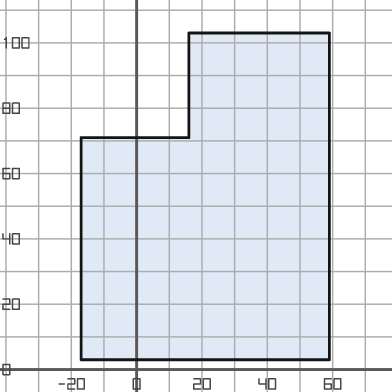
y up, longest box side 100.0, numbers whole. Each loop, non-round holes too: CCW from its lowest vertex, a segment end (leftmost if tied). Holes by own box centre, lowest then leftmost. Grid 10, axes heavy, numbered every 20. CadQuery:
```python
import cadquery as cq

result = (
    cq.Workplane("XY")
    .moveTo(-17.0, 3.0)
    .lineTo(59.0, 3.0)
    .lineTo(59.0, 103.0)
    .lineTo(16.0, 103.0)
    .lineTo(16.0, 71.0)
    .lineTo(-17.0, 71.0)
    .close()
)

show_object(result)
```